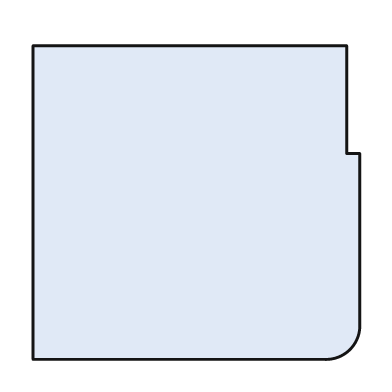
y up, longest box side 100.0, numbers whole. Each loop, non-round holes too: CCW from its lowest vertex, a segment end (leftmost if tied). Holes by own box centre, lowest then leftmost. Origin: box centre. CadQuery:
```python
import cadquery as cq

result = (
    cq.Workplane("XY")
    .moveTo(-50.0, -48.0)
    .lineTo(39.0, -48.0)
    .threePointArc((47.0, -45.0), (50.0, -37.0))
    .lineTo(50.0, 15.0)
    .lineTo(46.0, 15.0)
    .lineTo(46.0, 48.0)
    .lineTo(-50.0, 48.0)
    .close()
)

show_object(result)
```